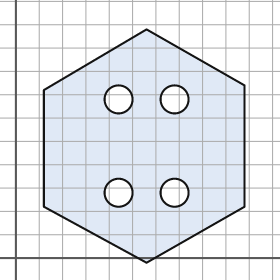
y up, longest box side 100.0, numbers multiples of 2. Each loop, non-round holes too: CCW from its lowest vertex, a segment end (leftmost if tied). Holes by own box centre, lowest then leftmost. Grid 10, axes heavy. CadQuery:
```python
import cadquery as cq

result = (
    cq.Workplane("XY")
    .moveTo(56.0, -2.0)
    .lineTo(98.0, 22.0)
    .lineTo(98.0, 74.0)
    .lineTo(56.0, 98.0)
    .lineTo(12.0, 72.0)
    .lineTo(12.0, 22.0)
    .close()
    .moveTo(44.0, 28.0)
    .circle(6.0)
    .moveTo(68.0, 28.0)
    .circle(6.0)
    .moveTo(44.0, 68.0)
    .circle(6.0)
    .moveTo(68.0, 68.0)
    .circle(6.0)
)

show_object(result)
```